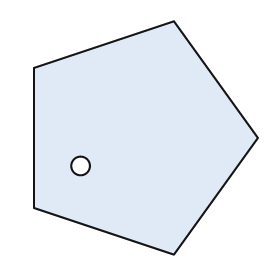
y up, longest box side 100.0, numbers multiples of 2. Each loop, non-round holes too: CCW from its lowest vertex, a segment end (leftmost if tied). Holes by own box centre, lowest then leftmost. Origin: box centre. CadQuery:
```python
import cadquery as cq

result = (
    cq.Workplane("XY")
    .moveTo(12.0, -50.0)
    .lineTo(48.0, 0.0)
    .lineTo(12.0, 50.0)
    .lineTo(-48.0, 30.0)
    .lineTo(-48.0, -30.0)
    .close()
    .moveTo(-28.0, -12.0)
    .circle(4.0)
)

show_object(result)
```